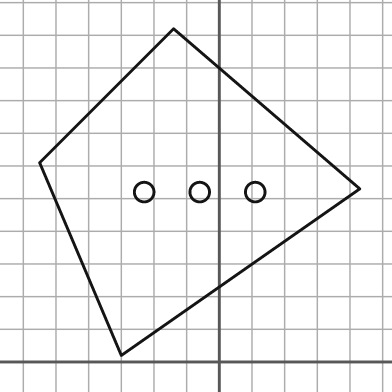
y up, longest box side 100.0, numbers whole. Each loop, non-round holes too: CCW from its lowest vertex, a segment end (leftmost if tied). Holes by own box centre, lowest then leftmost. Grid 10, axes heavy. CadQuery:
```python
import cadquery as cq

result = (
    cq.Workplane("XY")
    .moveTo(-30.0, 2.0)
    .lineTo(43.0, 53.0)
    .lineTo(-14.0, 102.0)
    .lineTo(-55.0, 61.0)
    .close()
    .moveTo(-23.0, 52.0)
    .circle(3.0)
    .moveTo(-6.0, 52.0)
    .circle(3.0)
    .moveTo(11.0, 52.0)
    .circle(3.0)
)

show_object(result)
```